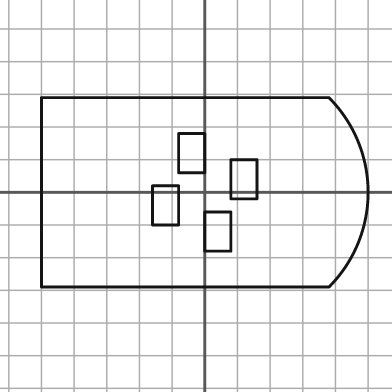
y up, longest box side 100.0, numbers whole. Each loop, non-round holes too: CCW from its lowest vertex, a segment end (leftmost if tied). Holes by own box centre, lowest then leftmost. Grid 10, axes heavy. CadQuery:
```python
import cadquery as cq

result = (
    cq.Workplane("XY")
    .moveTo(-50.0, -29.0)
    .lineTo(38.0, -29.0)
    .threePointArc((50.0, 0.0), (38.0, 29.0))
    .lineTo(-50.0, 29.0)
    .close()
    .moveTo(0.0, -18.0)
    .lineTo(8.0, -18.0)
    .lineTo(8.0, -6.0)
    .lineTo(0.0, -6.0)
    .close()
    .moveTo(-16.0, -10.0)
    .lineTo(-8.0, -10.0)
    .lineTo(-8.0, 2.0)
    .lineTo(-16.0, 2.0)
    .close()
    .moveTo(8.0, -2.0)
    .lineTo(16.0, -2.0)
    .lineTo(16.0, 10.0)
    .lineTo(8.0, 10.0)
    .close()
    .moveTo(-8.0, 6.0)
    .lineTo(0.0, 6.0)
    .lineTo(0.0, 18.0)
    .lineTo(-8.0, 18.0)
    .close()
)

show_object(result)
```